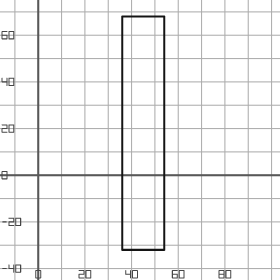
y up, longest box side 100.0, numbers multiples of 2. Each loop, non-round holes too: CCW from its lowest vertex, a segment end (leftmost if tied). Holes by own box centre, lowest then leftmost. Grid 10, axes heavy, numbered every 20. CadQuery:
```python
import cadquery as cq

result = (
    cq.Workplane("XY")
    .moveTo(36.0, -32.0)
    .lineTo(54.0, -32.0)
    .lineTo(54.0, 68.0)
    .lineTo(36.0, 68.0)
    .close()
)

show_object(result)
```